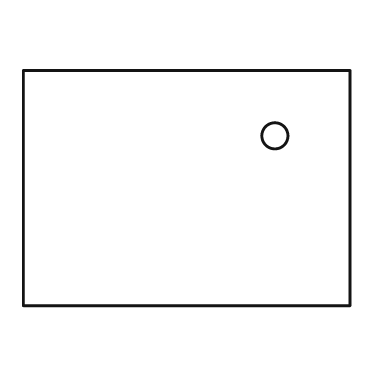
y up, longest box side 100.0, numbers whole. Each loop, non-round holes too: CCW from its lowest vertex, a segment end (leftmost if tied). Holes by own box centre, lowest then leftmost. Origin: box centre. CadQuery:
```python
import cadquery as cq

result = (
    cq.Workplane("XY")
    .moveTo(-50.0, -36.0)
    .lineTo(50.0, -36.0)
    .lineTo(50.0, 36.0)
    .lineTo(-50.0, 36.0)
    .close()
    .moveTo(27.0, 16.0)
    .circle(4.0)
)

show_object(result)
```